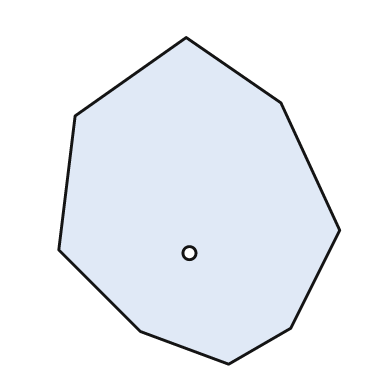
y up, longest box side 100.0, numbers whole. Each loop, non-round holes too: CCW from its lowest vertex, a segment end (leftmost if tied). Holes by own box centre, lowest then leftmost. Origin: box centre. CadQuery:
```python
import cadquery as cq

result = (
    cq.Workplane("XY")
    .moveTo(9.0, -50.0)
    .lineTo(28.0, -39.0)
    .lineTo(43.0, -9.0)
    .lineTo(25.0, 30.0)
    .lineTo(-4.0, 50.0)
    .lineTo(-38.0, 26.0)
    .lineTo(-43.0, -15.0)
    .lineTo(-18.0, -40.0)
    .close()
    .moveTo(-3.0, -16.0)
    .circle(2.0)
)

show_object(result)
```